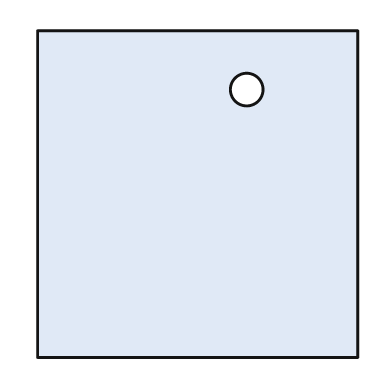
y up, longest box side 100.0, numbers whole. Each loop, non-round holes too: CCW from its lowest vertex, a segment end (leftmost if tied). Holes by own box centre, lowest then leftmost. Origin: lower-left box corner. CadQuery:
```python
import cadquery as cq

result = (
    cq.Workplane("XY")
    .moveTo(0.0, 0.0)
    .lineTo(98.0, 0.0)
    .lineTo(98.0, 100.0)
    .lineTo(0.0, 100.0)
    .close()
    .moveTo(64.0, 82.0)
    .circle(5.0)
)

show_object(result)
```